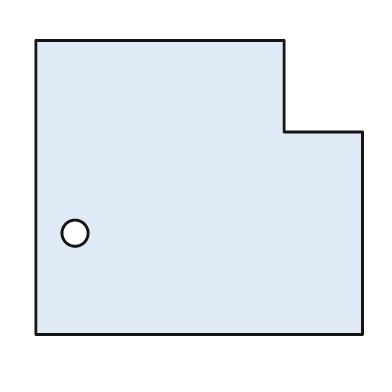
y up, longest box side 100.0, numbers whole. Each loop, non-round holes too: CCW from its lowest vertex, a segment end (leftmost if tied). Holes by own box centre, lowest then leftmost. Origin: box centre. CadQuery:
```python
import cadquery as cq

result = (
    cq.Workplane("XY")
    .moveTo(-50.0, -45.0)
    .lineTo(50.0, -45.0)
    .lineTo(50.0, 17.0)
    .lineTo(26.0, 17.0)
    .lineTo(26.0, 45.0)
    .lineTo(-50.0, 45.0)
    .close()
    .moveTo(-38.0, -14.0)
    .circle(4.0)
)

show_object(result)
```